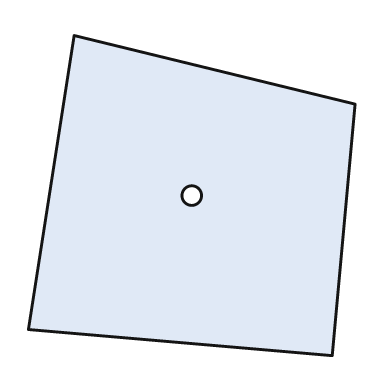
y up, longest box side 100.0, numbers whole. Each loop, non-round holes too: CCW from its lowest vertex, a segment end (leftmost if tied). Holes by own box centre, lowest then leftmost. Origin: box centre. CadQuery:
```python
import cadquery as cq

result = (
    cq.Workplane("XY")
    .moveTo(43.0, -49.0)
    .lineTo(50.0, 28.0)
    .lineTo(-36.0, 49.0)
    .lineTo(-50.0, -41.0)
    .close()
    .moveTo(0.0, 0.0)
    .circle(3.0)
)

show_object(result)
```